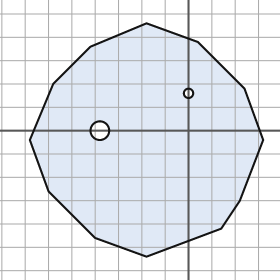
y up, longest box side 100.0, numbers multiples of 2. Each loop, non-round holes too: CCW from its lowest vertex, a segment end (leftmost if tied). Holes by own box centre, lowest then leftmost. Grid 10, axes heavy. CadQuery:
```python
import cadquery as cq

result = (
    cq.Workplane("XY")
    .moveTo(-18.0, -54.0)
    .lineTo(14.0, -42.0)
    .lineTo(22.0, -30.0)
    .lineTo(32.0, -4.0)
    .lineTo(24.0, 18.0)
    .lineTo(4.0, 38.0)
    .lineTo(-18.0, 46.0)
    .lineTo(-42.0, 36.0)
    .lineTo(-58.0, 20.0)
    .lineTo(-68.0, -4.0)
    .lineTo(-60.0, -26.0)
    .lineTo(-40.0, -46.0)
    .close()
    .moveTo(-38.0, 0.0)
    .circle(4.0)
    .moveTo(0.0, 16.0)
    .circle(2.0)
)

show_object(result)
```